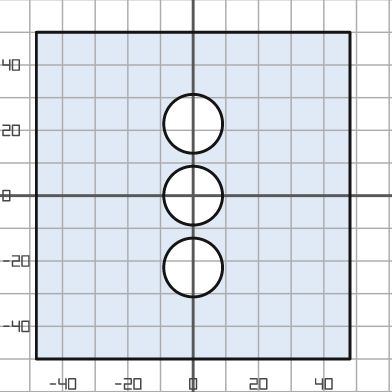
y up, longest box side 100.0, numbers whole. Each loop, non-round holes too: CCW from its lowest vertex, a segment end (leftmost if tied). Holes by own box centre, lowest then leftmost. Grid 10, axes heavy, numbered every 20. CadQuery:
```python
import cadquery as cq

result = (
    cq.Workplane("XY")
    .moveTo(-48.0, -50.0)
    .lineTo(48.0, -50.0)
    .lineTo(48.0, 50.0)
    .lineTo(-48.0, 50.0)
    .close()
    .moveTo(0.0, -22.0)
    .circle(9.0)
    .moveTo(0.0, 0.0)
    .circle(9.0)
    .moveTo(0.0, 22.0)
    .circle(9.0)
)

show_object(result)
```